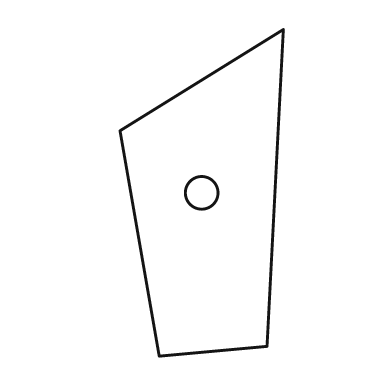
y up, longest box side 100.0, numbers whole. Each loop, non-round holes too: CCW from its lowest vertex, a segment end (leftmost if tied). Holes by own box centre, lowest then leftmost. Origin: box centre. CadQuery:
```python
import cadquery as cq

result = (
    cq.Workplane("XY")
    .moveTo(-13.0, -50.0)
    .lineTo(20.0, -47.0)
    .lineTo(25.0, 50.0)
    .lineTo(-25.0, 19.0)
    .close()
    .moveTo(0.0, 0.0)
    .circle(5.0)
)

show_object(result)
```